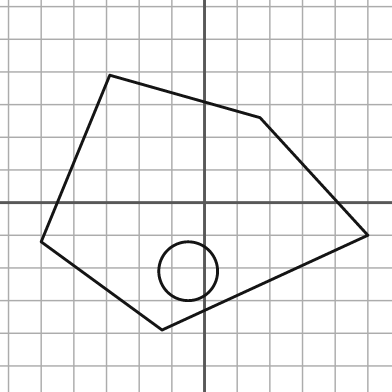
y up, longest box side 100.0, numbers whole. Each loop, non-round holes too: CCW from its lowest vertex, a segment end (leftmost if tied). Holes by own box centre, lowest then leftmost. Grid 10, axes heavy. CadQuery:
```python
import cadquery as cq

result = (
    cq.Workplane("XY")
    .moveTo(-13.0, -39.0)
    .lineTo(50.0, -10.0)
    .lineTo(17.0, 26.0)
    .lineTo(-29.0, 39.0)
    .lineTo(-50.0, -12.0)
    .close()
    .moveTo(-5.0, -21.0)
    .circle(9.0)
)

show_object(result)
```